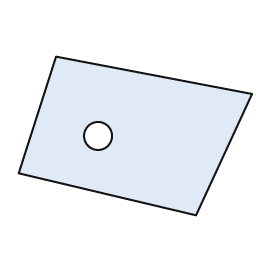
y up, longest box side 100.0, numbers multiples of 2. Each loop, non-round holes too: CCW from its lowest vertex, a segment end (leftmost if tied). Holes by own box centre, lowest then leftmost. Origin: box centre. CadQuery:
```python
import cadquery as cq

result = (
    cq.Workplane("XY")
    .moveTo(26.0, -34.0)
    .lineTo(50.0, 18.0)
    .lineTo(-34.0, 34.0)
    .lineTo(-50.0, -16.0)
    .close()
    .moveTo(-16.0, 0.0)
    .circle(6.0)
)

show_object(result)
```